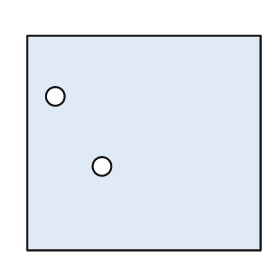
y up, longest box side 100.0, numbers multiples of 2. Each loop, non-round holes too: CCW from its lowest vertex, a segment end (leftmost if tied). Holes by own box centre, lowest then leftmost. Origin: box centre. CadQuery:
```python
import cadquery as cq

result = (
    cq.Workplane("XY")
    .moveTo(-50.0, -46.0)
    .lineTo(50.0, -46.0)
    .lineTo(50.0, 46.0)
    .lineTo(-50.0, 46.0)
    .close()
    .moveTo(-18.0, -10.0)
    .circle(4.0)
    .moveTo(-38.0, 20.0)
    .circle(4.0)
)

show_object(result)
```